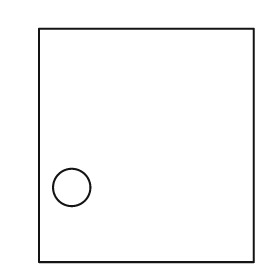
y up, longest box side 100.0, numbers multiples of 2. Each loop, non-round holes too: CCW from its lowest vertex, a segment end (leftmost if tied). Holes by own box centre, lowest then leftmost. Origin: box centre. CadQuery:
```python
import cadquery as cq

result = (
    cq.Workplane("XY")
    .moveTo(-46.0, -50.0)
    .lineTo(46.0, -50.0)
    .lineTo(46.0, 50.0)
    .lineTo(-46.0, 50.0)
    .close()
    .moveTo(-32.0, -18.0)
    .circle(8.0)
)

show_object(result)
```